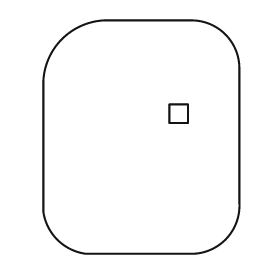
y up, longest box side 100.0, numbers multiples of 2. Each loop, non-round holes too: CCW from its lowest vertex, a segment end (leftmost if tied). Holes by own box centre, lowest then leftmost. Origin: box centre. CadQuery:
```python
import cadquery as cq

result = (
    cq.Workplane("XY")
    .moveTo(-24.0, -50.0)
    .lineTo(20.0, -50.0)
    .threePointArc((36.0, -44.0), (42.0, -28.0))
    .lineTo(42.0, 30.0)
    .threePointArc((36.0, 44.0), (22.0, 50.0))
    .lineTo(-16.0, 50.0)
    .threePointArc((-34.0, 42.0), (-42.0, 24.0))
    .lineTo(-42.0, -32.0)
    .threePointArc((-36.0, -44.0), (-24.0, -50.0))
    .close()
    .moveTo(12.0, 6.0)
    .lineTo(20.0, 6.0)
    .lineTo(20.0, 14.0)
    .lineTo(12.0, 14.0)
    .close()
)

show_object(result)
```